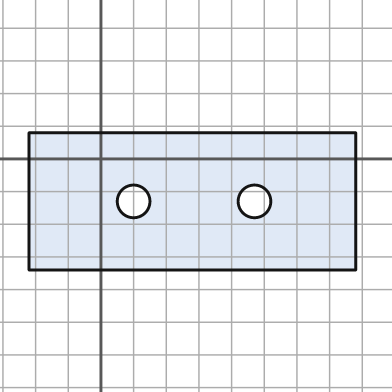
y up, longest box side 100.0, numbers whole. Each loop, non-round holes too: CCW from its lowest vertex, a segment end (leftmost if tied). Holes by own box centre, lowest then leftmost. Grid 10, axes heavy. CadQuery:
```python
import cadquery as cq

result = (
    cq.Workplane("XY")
    .moveTo(-22.0, -34.0)
    .lineTo(78.0, -34.0)
    .lineTo(78.0, 8.0)
    .lineTo(-22.0, 8.0)
    .close()
    .moveTo(10.0, -13.0)
    .circle(5.0)
    .moveTo(47.0, -13.0)
    .circle(5.0)
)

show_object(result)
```